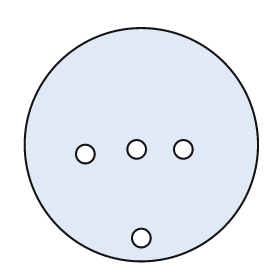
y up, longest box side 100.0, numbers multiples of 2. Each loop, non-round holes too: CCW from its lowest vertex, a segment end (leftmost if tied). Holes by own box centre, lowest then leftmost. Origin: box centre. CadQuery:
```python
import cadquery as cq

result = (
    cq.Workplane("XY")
    .moveTo(0.0, 0.0)
    .circle(50.0)
    .moveTo(0.0, -40.0)
    .circle(4.0)
    .moveTo(-24.0, -4.0)
    .circle(4.0)
    .moveTo(-2.0, -2.0)
    .circle(4.0)
    .moveTo(18.0, -2.0)
    .circle(4.0)
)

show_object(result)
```